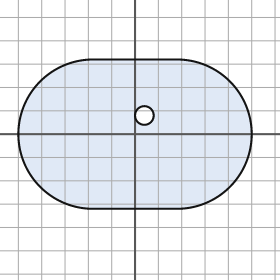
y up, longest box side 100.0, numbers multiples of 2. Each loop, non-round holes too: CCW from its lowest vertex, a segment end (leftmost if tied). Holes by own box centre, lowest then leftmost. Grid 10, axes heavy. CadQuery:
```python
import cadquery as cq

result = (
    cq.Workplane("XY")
    .moveTo(-18.0, -32.0)
    .lineTo(18.0, -32.0)
    .threePointArc((50.0, 0.0), (18.0, 32.0))
    .lineTo(-18.0, 32.0)
    .threePointArc((-50.0, 0.0), (-18.0, -32.0))
    .close()
    .moveTo(4.0, 8.0)
    .circle(4.0)
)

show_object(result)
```